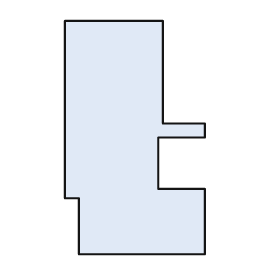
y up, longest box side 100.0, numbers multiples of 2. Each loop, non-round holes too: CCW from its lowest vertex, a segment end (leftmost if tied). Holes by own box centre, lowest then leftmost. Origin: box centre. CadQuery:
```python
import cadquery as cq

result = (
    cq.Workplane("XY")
    .moveTo(-24.0, -50.0)
    .lineTo(30.0, -50.0)
    .lineTo(30.0, -22.0)
    .lineTo(10.0, -22.0)
    .lineTo(10.0, 0.0)
    .lineTo(30.0, 0.0)
    .lineTo(30.0, 6.0)
    .lineTo(12.0, 6.0)
    .lineTo(12.0, 50.0)
    .lineTo(-30.0, 50.0)
    .lineTo(-30.0, -26.0)
    .lineTo(-24.0, -26.0)
    .close()
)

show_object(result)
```